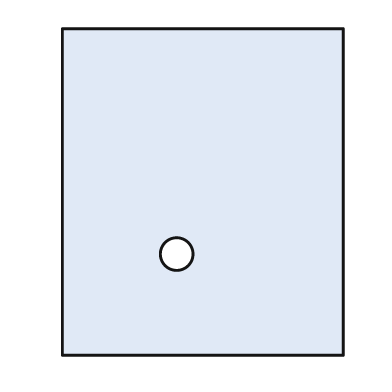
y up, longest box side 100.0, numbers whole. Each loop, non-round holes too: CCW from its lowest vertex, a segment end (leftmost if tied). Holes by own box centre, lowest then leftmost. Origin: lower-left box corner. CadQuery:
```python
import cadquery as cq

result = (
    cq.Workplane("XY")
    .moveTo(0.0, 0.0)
    .lineTo(86.0, 0.0)
    .lineTo(86.0, 100.0)
    .lineTo(0.0, 100.0)
    .close()
    .moveTo(35.0, 31.0)
    .circle(5.0)
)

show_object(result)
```